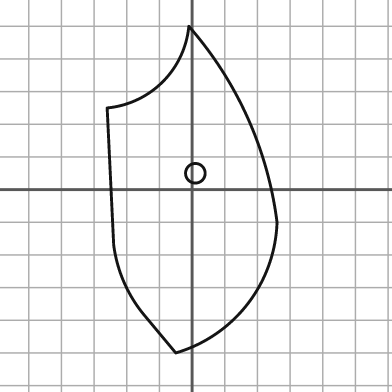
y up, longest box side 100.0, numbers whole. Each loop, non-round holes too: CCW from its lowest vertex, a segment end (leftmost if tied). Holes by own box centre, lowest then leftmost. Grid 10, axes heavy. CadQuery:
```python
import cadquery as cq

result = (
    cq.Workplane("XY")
    .moveTo(-5.0, -50.0)
    .threePointArc((17.0, -35.0), (26.0, -10.0))
    .threePointArc((17.0, 22.0), (-1.0, 50.0))
    .threePointArc((-9.0, 33.0), (-26.0, 25.0))
    .lineTo(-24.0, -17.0)
    .threePointArc((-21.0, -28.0), (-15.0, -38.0))
    .close()
    .moveTo(1.0, 5.0)
    .circle(3.0)
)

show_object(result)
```